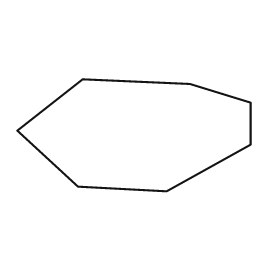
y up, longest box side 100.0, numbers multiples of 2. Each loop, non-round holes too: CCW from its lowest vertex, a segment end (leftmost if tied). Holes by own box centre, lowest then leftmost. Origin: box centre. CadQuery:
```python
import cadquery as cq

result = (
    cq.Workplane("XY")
    .moveTo(14.0, -24.0)
    .lineTo(50.0, -4.0)
    .lineTo(50.0, 14.0)
    .lineTo(24.0, 22.0)
    .lineTo(-22.0, 24.0)
    .lineTo(-50.0, 2.0)
    .lineTo(-24.0, -22.0)
    .close()
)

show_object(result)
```